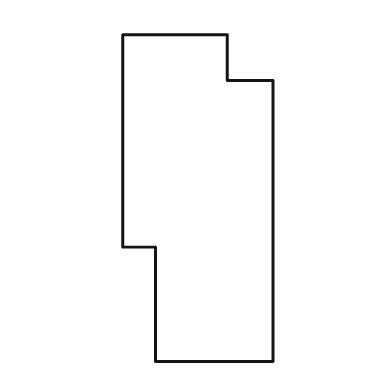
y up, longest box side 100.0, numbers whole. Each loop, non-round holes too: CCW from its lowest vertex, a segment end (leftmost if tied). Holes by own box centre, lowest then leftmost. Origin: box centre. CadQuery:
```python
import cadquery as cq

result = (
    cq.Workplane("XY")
    .moveTo(-13.0, -50.0)
    .lineTo(23.0, -50.0)
    .lineTo(23.0, 36.0)
    .lineTo(9.0, 36.0)
    .lineTo(9.0, 50.0)
    .lineTo(-23.0, 50.0)
    .lineTo(-23.0, -15.0)
    .lineTo(-13.0, -15.0)
    .close()
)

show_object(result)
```